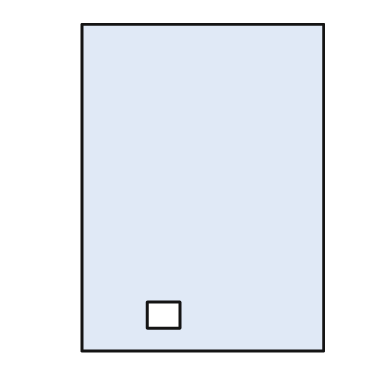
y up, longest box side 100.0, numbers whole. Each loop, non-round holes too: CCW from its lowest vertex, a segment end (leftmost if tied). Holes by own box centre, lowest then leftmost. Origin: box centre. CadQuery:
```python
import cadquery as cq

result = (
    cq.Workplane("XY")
    .moveTo(-37.0, -50.0)
    .lineTo(37.0, -50.0)
    .lineTo(37.0, 50.0)
    .lineTo(-37.0, 50.0)
    .close()
    .moveTo(-17.0, -43.0)
    .lineTo(-7.0, -43.0)
    .lineTo(-7.0, -35.0)
    .lineTo(-17.0, -35.0)
    .close()
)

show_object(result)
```